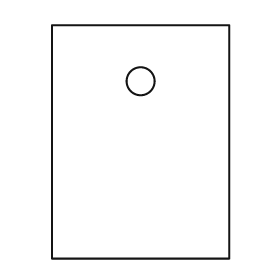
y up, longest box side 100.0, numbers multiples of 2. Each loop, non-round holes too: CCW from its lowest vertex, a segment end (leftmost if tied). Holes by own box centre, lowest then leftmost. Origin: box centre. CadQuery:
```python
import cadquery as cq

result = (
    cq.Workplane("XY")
    .moveTo(-38.0, -50.0)
    .lineTo(38.0, -50.0)
    .lineTo(38.0, 50.0)
    .lineTo(-38.0, 50.0)
    .close()
    .moveTo(0.0, 26.0)
    .circle(6.0)
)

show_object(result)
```